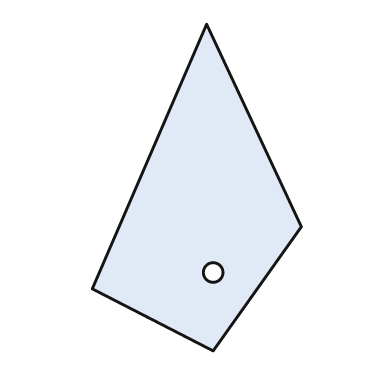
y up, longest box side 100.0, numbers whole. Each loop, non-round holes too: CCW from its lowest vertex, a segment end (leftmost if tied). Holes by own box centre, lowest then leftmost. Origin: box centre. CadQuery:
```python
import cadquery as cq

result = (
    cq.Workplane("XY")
    .moveTo(5.0, -50.0)
    .lineTo(32.0, -12.0)
    .lineTo(3.0, 50.0)
    .lineTo(-32.0, -31.0)
    .close()
    .moveTo(5.0, -26.0)
    .circle(3.0)
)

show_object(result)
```